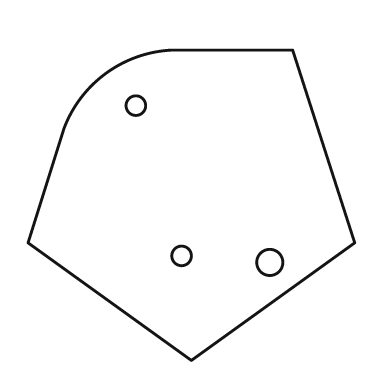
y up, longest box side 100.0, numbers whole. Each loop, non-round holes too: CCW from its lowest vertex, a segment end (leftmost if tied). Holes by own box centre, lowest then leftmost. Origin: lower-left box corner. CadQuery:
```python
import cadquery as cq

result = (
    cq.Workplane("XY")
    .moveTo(50.0, 0.0)
    .lineTo(100.0, 36.0)
    .lineTo(81.0, 95.0)
    .lineTo(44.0, 95.0)
    .threePointArc((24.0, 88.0), (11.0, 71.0))
    .lineTo(0.0, 36.0)
    .close()
    .moveTo(74.0, 30.0)
    .circle(4.0)
    .moveTo(47.0, 32.0)
    .circle(3.0)
    .moveTo(33.0, 78.0)
    .circle(3.0)
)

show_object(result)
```